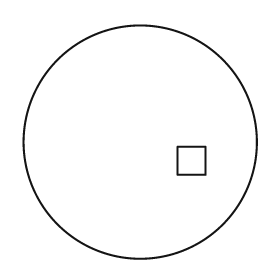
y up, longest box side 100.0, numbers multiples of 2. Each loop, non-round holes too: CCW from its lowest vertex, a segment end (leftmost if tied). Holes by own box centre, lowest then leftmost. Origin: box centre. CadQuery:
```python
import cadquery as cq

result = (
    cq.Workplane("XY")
    .moveTo(0.0, 0.0)
    .circle(50.0)
    .moveTo(16.0, -14.0)
    .lineTo(28.0, -14.0)
    .lineTo(28.0, -2.0)
    .lineTo(16.0, -2.0)
    .close()
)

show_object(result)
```